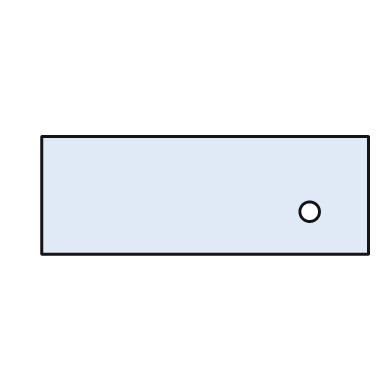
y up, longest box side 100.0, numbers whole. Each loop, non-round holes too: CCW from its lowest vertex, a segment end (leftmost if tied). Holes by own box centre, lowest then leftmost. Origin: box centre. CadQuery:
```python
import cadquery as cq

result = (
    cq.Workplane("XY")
    .moveTo(-50.0, -18.0)
    .lineTo(50.0, -18.0)
    .lineTo(50.0, 18.0)
    .lineTo(-50.0, 18.0)
    .close()
    .moveTo(32.0, -5.0)
    .circle(3.0)
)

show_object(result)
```